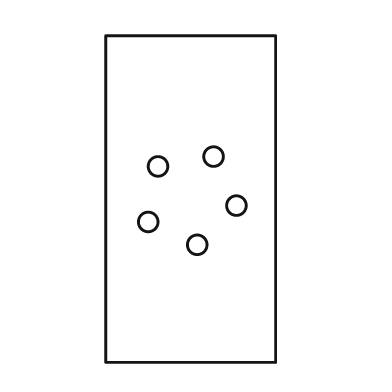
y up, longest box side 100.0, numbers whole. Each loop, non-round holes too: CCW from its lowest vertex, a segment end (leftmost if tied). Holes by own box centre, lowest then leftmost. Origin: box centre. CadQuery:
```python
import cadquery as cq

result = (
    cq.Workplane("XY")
    .moveTo(-26.0, -50.0)
    .lineTo(26.0, -50.0)
    .lineTo(26.0, 50.0)
    .lineTo(-26.0, 50.0)
    .close()
    .moveTo(2.0, -14.0)
    .circle(3.0)
    .moveTo(-13.0, -7.0)
    .circle(3.0)
    .moveTo(14.0, -2.0)
    .circle(3.0)
    .moveTo(-10.0, 10.0)
    .circle(3.0)
    .moveTo(7.0, 13.0)
    .circle(3.0)
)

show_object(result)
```